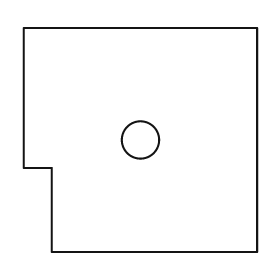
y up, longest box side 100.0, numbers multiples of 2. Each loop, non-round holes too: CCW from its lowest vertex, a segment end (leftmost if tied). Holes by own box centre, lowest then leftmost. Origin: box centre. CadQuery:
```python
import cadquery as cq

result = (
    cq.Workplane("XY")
    .moveTo(-38.0, -48.0)
    .lineTo(50.0, -48.0)
    .lineTo(50.0, 48.0)
    .lineTo(-50.0, 48.0)
    .lineTo(-50.0, -12.0)
    .lineTo(-38.0, -12.0)
    .close()
    .moveTo(0.0, 0.0)
    .circle(8.0)
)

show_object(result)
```